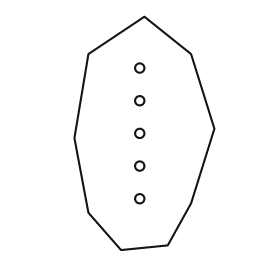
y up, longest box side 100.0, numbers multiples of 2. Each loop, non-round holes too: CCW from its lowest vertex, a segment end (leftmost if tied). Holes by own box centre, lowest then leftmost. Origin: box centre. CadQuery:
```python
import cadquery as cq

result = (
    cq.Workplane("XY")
    .moveTo(-10.0, -50.0)
    .lineTo(10.0, -48.0)
    .lineTo(20.0, -30.0)
    .lineTo(30.0, 2.0)
    .lineTo(20.0, 34.0)
    .lineTo(0.0, 50.0)
    .lineTo(-24.0, 34.0)
    .lineTo(-30.0, -2.0)
    .lineTo(-24.0, -34.0)
    .close()
    .moveTo(-2.0, -28.0)
    .circle(2.0)
    .moveTo(-2.0, -14.0)
    .circle(2.0)
    .moveTo(-2.0, 0.0)
    .circle(2.0)
    .moveTo(-2.0, 14.0)
    .circle(2.0)
    .moveTo(-2.0, 28.0)
    .circle(2.0)
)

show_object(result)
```